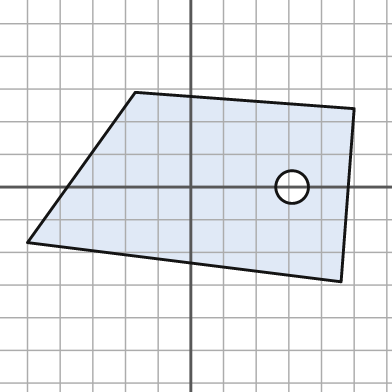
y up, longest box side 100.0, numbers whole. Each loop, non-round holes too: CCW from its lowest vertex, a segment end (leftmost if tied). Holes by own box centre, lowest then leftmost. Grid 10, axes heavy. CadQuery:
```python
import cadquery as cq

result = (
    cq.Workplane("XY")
    .moveTo(46.0, -29.0)
    .lineTo(50.0, 24.0)
    .lineTo(-17.0, 29.0)
    .lineTo(-50.0, -17.0)
    .close()
    .moveTo(31.0, 0.0)
    .circle(5.0)
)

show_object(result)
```